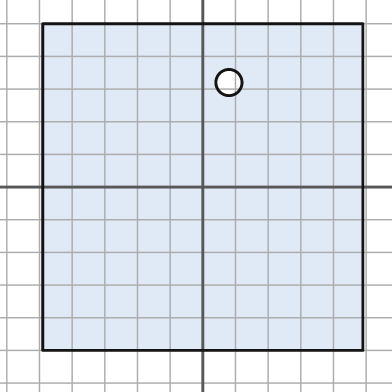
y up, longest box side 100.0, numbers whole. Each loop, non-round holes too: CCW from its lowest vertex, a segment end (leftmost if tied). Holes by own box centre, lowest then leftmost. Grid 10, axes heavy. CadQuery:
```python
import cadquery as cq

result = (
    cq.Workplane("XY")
    .moveTo(-49.0, -50.0)
    .lineTo(49.0, -50.0)
    .lineTo(49.0, 50.0)
    .lineTo(-49.0, 50.0)
    .close()
    .moveTo(8.0, 32.0)
    .circle(4.0)
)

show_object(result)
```